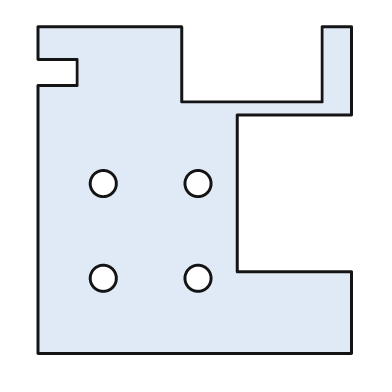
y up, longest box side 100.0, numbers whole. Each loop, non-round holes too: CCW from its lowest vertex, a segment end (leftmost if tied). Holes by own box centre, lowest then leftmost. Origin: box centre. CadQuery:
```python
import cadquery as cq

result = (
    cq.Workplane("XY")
    .moveTo(-48.0, -50.0)
    .lineTo(48.0, -50.0)
    .lineTo(48.0, -25.0)
    .lineTo(13.0, -25.0)
    .lineTo(13.0, 23.0)
    .lineTo(48.0, 23.0)
    .lineTo(48.0, 50.0)
    .lineTo(39.0, 50.0)
    .lineTo(39.0, 27.0)
    .lineTo(-4.0, 27.0)
    .lineTo(-4.0, 50.0)
    .lineTo(-48.0, 50.0)
    .lineTo(-48.0, 40.0)
    .lineTo(-36.0, 40.0)
    .lineTo(-36.0, 32.0)
    .lineTo(-48.0, 32.0)
    .close()
    .moveTo(-28.0, -27.0)
    .circle(4.0)
    .moveTo(1.0, -27.0)
    .circle(4.0)
    .moveTo(-28.0, 2.0)
    .circle(4.0)
    .moveTo(1.0, 2.0)
    .circle(4.0)
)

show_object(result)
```